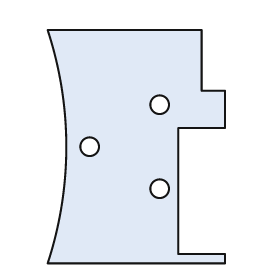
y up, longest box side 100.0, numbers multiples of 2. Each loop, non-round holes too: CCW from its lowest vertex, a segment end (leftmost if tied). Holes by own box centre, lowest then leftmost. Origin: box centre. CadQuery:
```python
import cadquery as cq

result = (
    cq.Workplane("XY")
    .moveTo(-38.0, -50.0)
    .lineTo(38.0, -50.0)
    .lineTo(38.0, -46.0)
    .lineTo(18.0, -46.0)
    .lineTo(18.0, 8.0)
    .lineTo(38.0, 8.0)
    .lineTo(38.0, 24.0)
    .lineTo(28.0, 24.0)
    .lineTo(28.0, 50.0)
    .lineTo(-38.0, 50.0)
    .threePointArc((-30.0, 0.0), (-38.0, -50.0))
    .close()
    .moveTo(10.0, -18.0)
    .circle(4.0)
    .moveTo(-20.0, 0.0)
    .circle(4.0)
    .moveTo(10.0, 18.0)
    .circle(4.0)
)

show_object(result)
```